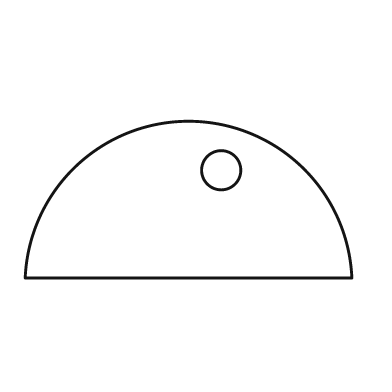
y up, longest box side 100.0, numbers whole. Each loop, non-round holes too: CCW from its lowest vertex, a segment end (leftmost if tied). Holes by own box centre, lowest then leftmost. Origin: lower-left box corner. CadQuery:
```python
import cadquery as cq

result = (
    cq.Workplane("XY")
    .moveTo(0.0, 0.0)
    .lineTo(100.0, 0.0)
    .threePointArc((50.0, 48.0), (0.0, 0.0))
    .close()
    .moveTo(60.0, 33.0)
    .circle(6.0)
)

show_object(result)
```